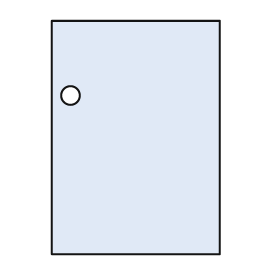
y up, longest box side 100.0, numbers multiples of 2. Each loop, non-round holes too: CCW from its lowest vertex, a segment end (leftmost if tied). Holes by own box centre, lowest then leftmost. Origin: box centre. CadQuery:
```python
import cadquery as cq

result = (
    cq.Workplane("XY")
    .moveTo(-36.0, -50.0)
    .lineTo(36.0, -50.0)
    .lineTo(36.0, 50.0)
    .lineTo(-36.0, 50.0)
    .close()
    .moveTo(-28.0, 18.0)
    .circle(4.0)
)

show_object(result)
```